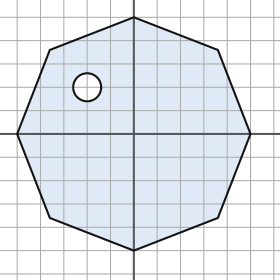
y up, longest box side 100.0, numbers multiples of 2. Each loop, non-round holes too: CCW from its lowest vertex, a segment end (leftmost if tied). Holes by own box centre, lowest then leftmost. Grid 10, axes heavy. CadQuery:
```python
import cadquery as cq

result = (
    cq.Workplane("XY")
    .moveTo(0.0, -50.0)
    .lineTo(36.0, -36.0)
    .lineTo(50.0, 0.0)
    .lineTo(36.0, 36.0)
    .lineTo(0.0, 50.0)
    .lineTo(-36.0, 36.0)
    .lineTo(-50.0, 0.0)
    .lineTo(-36.0, -36.0)
    .close()
    .moveTo(-20.0, 20.0)
    .circle(6.0)
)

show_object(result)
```